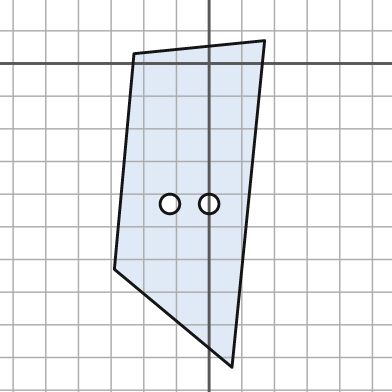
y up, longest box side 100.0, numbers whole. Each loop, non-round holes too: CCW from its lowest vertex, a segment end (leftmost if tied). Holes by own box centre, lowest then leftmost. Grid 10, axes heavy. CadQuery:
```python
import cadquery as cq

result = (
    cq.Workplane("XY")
    .moveTo(7.0, -93.0)
    .lineTo(17.0, 7.0)
    .lineTo(-23.0, 3.0)
    .lineTo(-29.0, -63.0)
    .close()
    .moveTo(-12.0, -43.0)
    .circle(3.0)
    .moveTo(0.0, -43.0)
    .circle(3.0)
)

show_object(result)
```